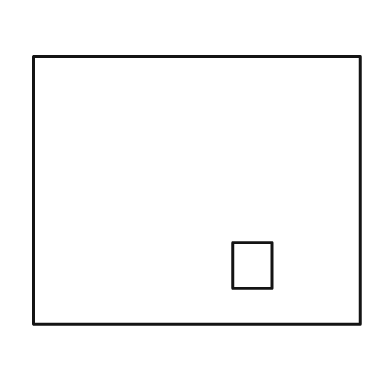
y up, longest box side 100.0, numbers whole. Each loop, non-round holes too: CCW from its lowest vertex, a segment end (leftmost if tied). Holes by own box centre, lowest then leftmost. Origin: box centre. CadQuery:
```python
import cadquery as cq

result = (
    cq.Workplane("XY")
    .moveTo(-50.0, -41.0)
    .lineTo(50.0, -41.0)
    .lineTo(50.0, 41.0)
    .lineTo(-50.0, 41.0)
    .close()
    .moveTo(11.0, -30.0)
    .lineTo(23.0, -30.0)
    .lineTo(23.0, -16.0)
    .lineTo(11.0, -16.0)
    .close()
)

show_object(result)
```